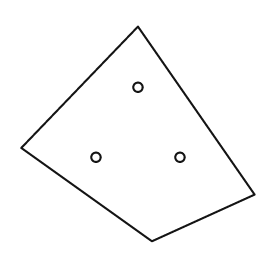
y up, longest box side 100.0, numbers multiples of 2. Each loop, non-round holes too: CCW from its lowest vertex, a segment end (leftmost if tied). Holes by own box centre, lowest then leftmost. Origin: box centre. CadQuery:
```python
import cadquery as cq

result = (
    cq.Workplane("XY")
    .moveTo(6.0, -46.0)
    .lineTo(50.0, -26.0)
    .lineTo(0.0, 46.0)
    .lineTo(-50.0, -6.0)
    .close()
    .moveTo(-18.0, -10.0)
    .circle(2.0)
    .moveTo(18.0, -10.0)
    .circle(2.0)
    .moveTo(0.0, 20.0)
    .circle(2.0)
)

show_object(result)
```